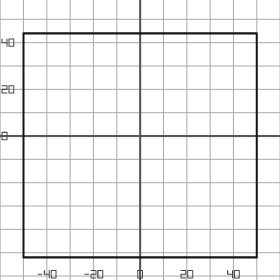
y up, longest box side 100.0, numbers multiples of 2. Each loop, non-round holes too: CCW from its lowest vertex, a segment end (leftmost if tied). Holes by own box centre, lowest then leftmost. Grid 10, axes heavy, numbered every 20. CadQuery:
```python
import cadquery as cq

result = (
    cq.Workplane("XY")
    .moveTo(-50.0, -52.0)
    .lineTo(50.0, -52.0)
    .lineTo(50.0, 44.0)
    .lineTo(-50.0, 44.0)
    .close()
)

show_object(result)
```